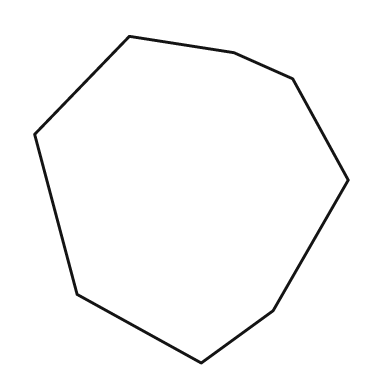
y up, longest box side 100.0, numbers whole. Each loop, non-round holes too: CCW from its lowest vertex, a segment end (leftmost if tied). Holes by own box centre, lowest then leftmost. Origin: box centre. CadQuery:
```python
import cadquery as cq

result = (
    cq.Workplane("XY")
    .moveTo(3.0, -50.0)
    .lineTo(25.0, -34.0)
    .lineTo(48.0, 6.0)
    .lineTo(31.0, 37.0)
    .lineTo(13.0, 45.0)
    .lineTo(-19.0, 50.0)
    .lineTo(-48.0, 20.0)
    .lineTo(-35.0, -29.0)
    .close()
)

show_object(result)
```